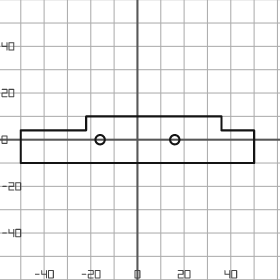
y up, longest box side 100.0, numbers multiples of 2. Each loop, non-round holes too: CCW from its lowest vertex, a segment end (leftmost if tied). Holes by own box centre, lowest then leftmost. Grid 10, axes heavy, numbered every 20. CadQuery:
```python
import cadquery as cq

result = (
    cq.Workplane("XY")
    .moveTo(-50.0, -10.0)
    .lineTo(50.0, -10.0)
    .lineTo(50.0, 4.0)
    .lineTo(36.0, 4.0)
    .lineTo(36.0, 10.0)
    .lineTo(-22.0, 10.0)
    .lineTo(-22.0, 4.0)
    .lineTo(-50.0, 4.0)
    .close()
    .moveTo(-16.0, 0.0)
    .circle(2.0)
    .moveTo(16.0, 0.0)
    .circle(2.0)
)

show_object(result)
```